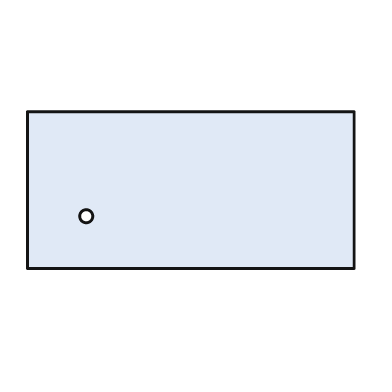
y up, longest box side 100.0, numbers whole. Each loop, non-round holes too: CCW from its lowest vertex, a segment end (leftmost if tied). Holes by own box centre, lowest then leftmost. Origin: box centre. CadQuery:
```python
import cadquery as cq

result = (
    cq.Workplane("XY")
    .moveTo(-50.0, -24.0)
    .lineTo(50.0, -24.0)
    .lineTo(50.0, 24.0)
    .lineTo(-50.0, 24.0)
    .close()
    .moveTo(-32.0, -8.0)
    .circle(2.0)
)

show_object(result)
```